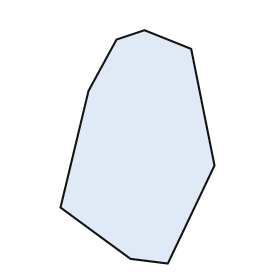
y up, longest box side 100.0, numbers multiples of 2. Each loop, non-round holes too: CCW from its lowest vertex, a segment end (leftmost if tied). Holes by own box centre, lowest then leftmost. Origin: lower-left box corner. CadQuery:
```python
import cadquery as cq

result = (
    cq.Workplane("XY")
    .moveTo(46.0, 0.0)
    .lineTo(66.0, 42.0)
    .lineTo(56.0, 92.0)
    .lineTo(36.0, 100.0)
    .lineTo(24.0, 96.0)
    .lineTo(12.0, 74.0)
    .lineTo(0.0, 24.0)
    .lineTo(30.0, 2.0)
    .close()
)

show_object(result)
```